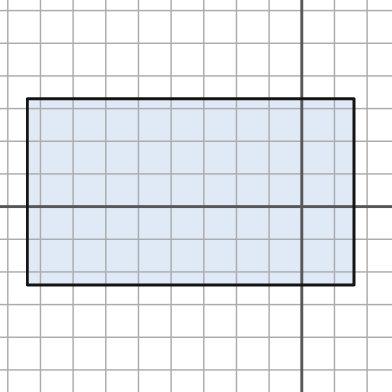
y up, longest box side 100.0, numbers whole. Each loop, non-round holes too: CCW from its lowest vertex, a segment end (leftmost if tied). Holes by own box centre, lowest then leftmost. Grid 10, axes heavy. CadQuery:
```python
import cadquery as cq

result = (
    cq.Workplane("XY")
    .moveTo(-84.0, -24.0)
    .lineTo(16.0, -24.0)
    .lineTo(16.0, 33.0)
    .lineTo(-84.0, 33.0)
    .close()
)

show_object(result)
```